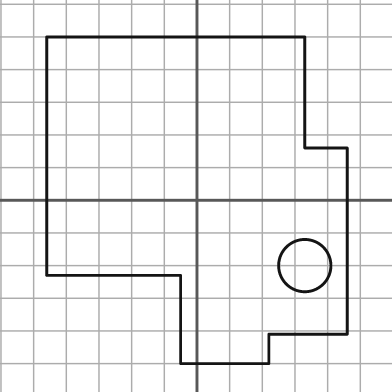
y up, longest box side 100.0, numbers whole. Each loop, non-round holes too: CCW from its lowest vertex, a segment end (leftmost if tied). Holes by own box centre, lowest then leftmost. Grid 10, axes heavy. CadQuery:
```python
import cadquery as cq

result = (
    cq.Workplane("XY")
    .moveTo(-5.0, -50.0)
    .lineTo(22.0, -50.0)
    .lineTo(22.0, -41.0)
    .lineTo(46.0, -41.0)
    .lineTo(46.0, 16.0)
    .lineTo(33.0, 16.0)
    .lineTo(33.0, 50.0)
    .lineTo(-46.0, 50.0)
    .lineTo(-46.0, -23.0)
    .lineTo(-5.0, -23.0)
    .close()
    .moveTo(33.0, -20.0)
    .circle(8.0)
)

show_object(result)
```